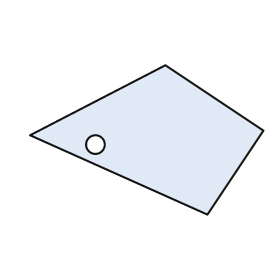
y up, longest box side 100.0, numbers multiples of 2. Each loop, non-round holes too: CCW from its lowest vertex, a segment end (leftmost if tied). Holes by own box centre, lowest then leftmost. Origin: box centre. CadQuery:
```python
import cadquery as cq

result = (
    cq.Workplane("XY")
    .moveTo(26.0, -32.0)
    .lineTo(50.0, 4.0)
    .lineTo(8.0, 32.0)
    .lineTo(-50.0, 2.0)
    .close()
    .moveTo(-22.0, -2.0)
    .circle(4.0)
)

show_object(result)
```